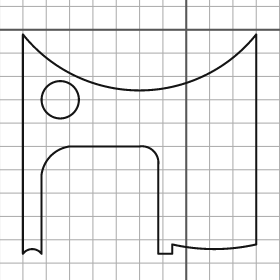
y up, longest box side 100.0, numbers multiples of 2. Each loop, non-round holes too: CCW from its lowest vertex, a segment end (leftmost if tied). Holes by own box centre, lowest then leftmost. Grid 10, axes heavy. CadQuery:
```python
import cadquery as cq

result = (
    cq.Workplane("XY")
    .moveTo(-70.0, -96.0)
    .threePointArc((-66.0, -94.0), (-62.0, -96.0))
    .lineTo(-62.0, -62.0)
    .threePointArc((-58.0, -54.0), (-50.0, -50.0))
    .lineTo(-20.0, -50.0)
    .threePointArc((-14.0, -52.0), (-12.0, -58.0))
    .lineTo(-12.0, -96.0)
    .lineTo(-6.0, -96.0)
    .lineTo(-6.0, -92.0)
    .threePointArc((12.0, -94.0), (30.0, -92.0))
    .lineTo(30.0, -2.0)
    .threePointArc((-20.0, -26.0), (-70.0, -2.0))
    .close()
    .moveTo(-54.0, -30.0)
    .circle(8.0)
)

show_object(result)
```